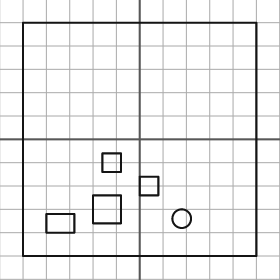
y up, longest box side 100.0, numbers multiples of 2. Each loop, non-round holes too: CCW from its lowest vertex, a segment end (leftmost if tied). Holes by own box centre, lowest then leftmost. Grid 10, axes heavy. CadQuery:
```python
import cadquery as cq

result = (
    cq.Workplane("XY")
    .moveTo(-50.0, -50.0)
    .lineTo(50.0, -50.0)
    .lineTo(50.0, 50.0)
    .lineTo(-50.0, 50.0)
    .close()
    .moveTo(-40.0, -40.0)
    .lineTo(-28.0, -40.0)
    .lineTo(-28.0, -32.0)
    .lineTo(-40.0, -32.0)
    .close()
    .moveTo(18.0, -34.0)
    .circle(4.0)
    .moveTo(-20.0, -36.0)
    .lineTo(-8.0, -36.0)
    .lineTo(-8.0, -24.0)
    .lineTo(-20.0, -24.0)
    .close()
    .moveTo(0.0, -24.0)
    .lineTo(8.0, -24.0)
    .lineTo(8.0, -16.0)
    .lineTo(0.0, -16.0)
    .close()
    .moveTo(-16.0, -14.0)
    .lineTo(-8.0, -14.0)
    .lineTo(-8.0, -6.0)
    .lineTo(-16.0, -6.0)
    .close()
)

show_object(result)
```